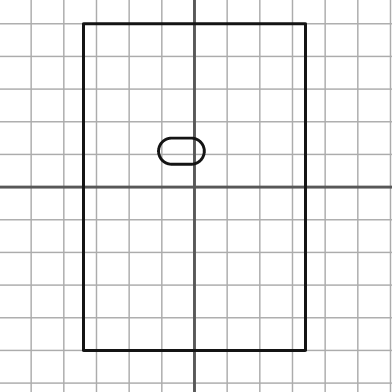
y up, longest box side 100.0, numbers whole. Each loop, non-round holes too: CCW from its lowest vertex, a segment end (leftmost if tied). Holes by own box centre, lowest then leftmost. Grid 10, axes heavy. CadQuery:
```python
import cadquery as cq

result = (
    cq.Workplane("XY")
    .moveTo(-34.0, -50.0)
    .lineTo(34.0, -50.0)
    .lineTo(34.0, 50.0)
    .lineTo(-34.0, 50.0)
    .close()
    .moveTo(-7.0, 7.0)
    .lineTo(-1.0, 7.0)
    .threePointArc((3.0, 11.0), (-1.0, 15.0))
    .lineTo(-7.0, 15.0)
    .threePointArc((-11.0, 11.0), (-7.0, 7.0))
    .close()
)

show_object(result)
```